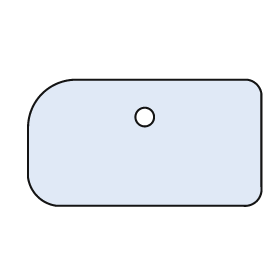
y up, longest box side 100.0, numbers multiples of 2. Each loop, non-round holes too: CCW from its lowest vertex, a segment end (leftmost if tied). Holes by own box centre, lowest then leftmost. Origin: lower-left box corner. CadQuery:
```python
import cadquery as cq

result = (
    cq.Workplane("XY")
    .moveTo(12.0, 0.0)
    .lineTo(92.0, 0.0)
    .threePointArc((98.0, 2.0), (100.0, 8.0))
    .lineTo(100.0, 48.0)
    .threePointArc((98.0, 52.0), (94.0, 54.0))
    .lineTo(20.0, 54.0)
    .threePointArc((6.0, 48.0), (0.0, 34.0))
    .lineTo(0.0, 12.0)
    .threePointArc((4.0, 4.0), (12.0, 0.0))
    .close()
    .moveTo(50.0, 38.0)
    .circle(4.0)
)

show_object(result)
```